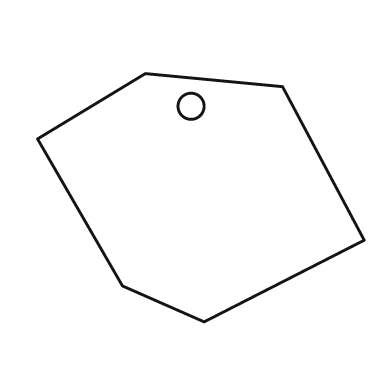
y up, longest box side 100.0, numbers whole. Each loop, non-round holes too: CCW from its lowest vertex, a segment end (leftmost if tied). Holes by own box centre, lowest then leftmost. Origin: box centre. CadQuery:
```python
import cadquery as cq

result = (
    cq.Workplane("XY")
    .moveTo(1.0, -38.0)
    .lineTo(50.0, -13.0)
    .lineTo(25.0, 34.0)
    .lineTo(-17.0, 38.0)
    .lineTo(-50.0, 18.0)
    .lineTo(-24.0, -27.0)
    .close()
    .moveTo(-3.0, 28.0)
    .circle(4.0)
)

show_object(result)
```